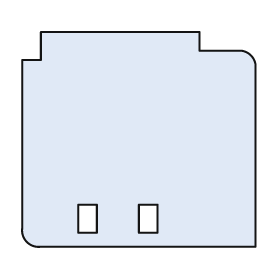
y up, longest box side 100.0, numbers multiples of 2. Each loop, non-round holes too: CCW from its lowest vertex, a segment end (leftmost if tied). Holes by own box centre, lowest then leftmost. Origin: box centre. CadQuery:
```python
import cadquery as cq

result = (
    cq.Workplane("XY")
    .moveTo(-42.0, -46.0)
    .lineTo(50.0, -46.0)
    .lineTo(50.0, 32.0)
    .threePointArc((48.0, 36.0), (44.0, 38.0))
    .lineTo(26.0, 38.0)
    .lineTo(26.0, 46.0)
    .lineTo(-42.0, 46.0)
    .lineTo(-42.0, 34.0)
    .lineTo(-50.0, 34.0)
    .lineTo(-50.0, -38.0)
    .threePointArc((-48.0, -44.0), (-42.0, -46.0))
    .close()
    .moveTo(-26.0, -40.0)
    .lineTo(-18.0, -40.0)
    .lineTo(-18.0, -28.0)
    .lineTo(-26.0, -28.0)
    .close()
    .moveTo(0.0, -40.0)
    .lineTo(8.0, -40.0)
    .lineTo(8.0, -28.0)
    .lineTo(0.0, -28.0)
    .close()
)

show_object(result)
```